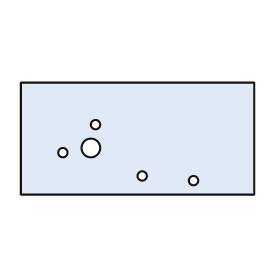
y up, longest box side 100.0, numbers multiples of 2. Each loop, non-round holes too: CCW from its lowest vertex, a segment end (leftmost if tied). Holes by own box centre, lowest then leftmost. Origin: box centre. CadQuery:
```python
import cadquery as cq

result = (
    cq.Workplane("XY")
    .moveTo(-50.0, -24.0)
    .lineTo(50.0, -24.0)
    .lineTo(50.0, 24.0)
    .lineTo(-50.0, 24.0)
    .close()
    .moveTo(24.0, -18.0)
    .circle(2.0)
    .moveTo(2.0, -16.0)
    .circle(2.0)
    .moveTo(-32.0, -6.0)
    .circle(2.0)
    .moveTo(-20.0, -4.0)
    .circle(4.0)
    .moveTo(-18.0, 6.0)
    .circle(2.0)
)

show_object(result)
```